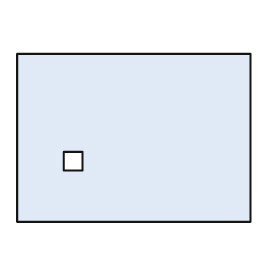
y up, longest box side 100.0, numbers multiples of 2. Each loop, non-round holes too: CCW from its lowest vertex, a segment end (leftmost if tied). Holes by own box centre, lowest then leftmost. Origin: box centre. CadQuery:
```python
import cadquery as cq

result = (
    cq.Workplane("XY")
    .moveTo(-50.0, -36.0)
    .lineTo(50.0, -36.0)
    .lineTo(50.0, 36.0)
    .lineTo(-50.0, 36.0)
    .close()
    .moveTo(-30.0, -14.0)
    .lineTo(-22.0, -14.0)
    .lineTo(-22.0, -6.0)
    .lineTo(-30.0, -6.0)
    .close()
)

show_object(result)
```